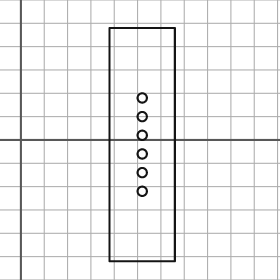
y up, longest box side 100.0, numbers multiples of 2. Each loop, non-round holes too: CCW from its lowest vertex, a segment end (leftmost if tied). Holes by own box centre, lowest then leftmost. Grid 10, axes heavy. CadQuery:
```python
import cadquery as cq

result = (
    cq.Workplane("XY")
    .moveTo(38.0, -52.0)
    .lineTo(66.0, -52.0)
    .lineTo(66.0, 48.0)
    .lineTo(38.0, 48.0)
    .close()
    .moveTo(52.0, -22.0)
    .circle(2.0)
    .moveTo(52.0, -14.0)
    .circle(2.0)
    .moveTo(52.0, -6.0)
    .circle(2.0)
    .moveTo(52.0, 2.0)
    .circle(2.0)
    .moveTo(52.0, 10.0)
    .circle(2.0)
    .moveTo(52.0, 18.0)
    .circle(2.0)
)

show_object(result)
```